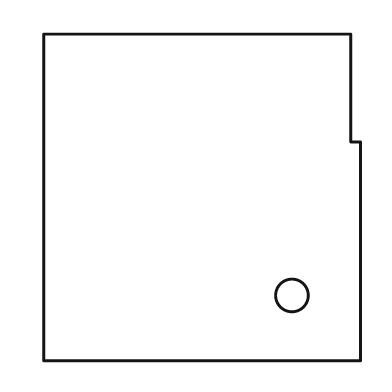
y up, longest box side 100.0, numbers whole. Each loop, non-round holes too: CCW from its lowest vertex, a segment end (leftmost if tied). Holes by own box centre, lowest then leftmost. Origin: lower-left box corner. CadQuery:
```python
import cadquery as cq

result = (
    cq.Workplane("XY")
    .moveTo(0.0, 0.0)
    .lineTo(97.0, 0.0)
    .lineTo(97.0, 67.0)
    .lineTo(94.0, 67.0)
    .lineTo(94.0, 100.0)
    .lineTo(0.0, 100.0)
    .close()
    .moveTo(76.0, 20.0)
    .circle(5.0)
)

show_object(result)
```